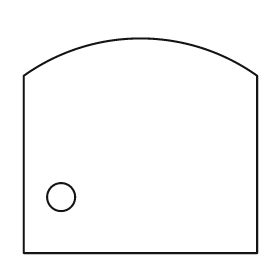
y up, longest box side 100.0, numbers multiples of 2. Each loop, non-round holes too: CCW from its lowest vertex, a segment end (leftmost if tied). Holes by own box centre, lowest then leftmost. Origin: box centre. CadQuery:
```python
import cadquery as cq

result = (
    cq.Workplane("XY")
    .moveTo(-50.0, -46.0)
    .lineTo(50.0, -46.0)
    .lineTo(50.0, 30.0)
    .threePointArc((0.0, 46.0), (-50.0, 30.0))
    .close()
    .moveTo(-34.0, -22.0)
    .circle(6.0)
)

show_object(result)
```